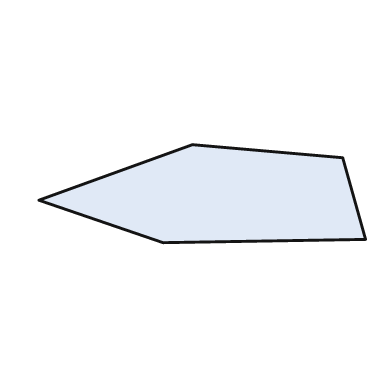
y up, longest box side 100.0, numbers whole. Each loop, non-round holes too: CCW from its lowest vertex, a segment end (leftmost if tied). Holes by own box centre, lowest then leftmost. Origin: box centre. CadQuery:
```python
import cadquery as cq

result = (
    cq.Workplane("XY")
    .moveTo(-12.0, -15.0)
    .lineTo(50.0, -14.0)
    .lineTo(43.0, 11.0)
    .lineTo(-3.0, 15.0)
    .lineTo(-50.0, -2.0)
    .close()
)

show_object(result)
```